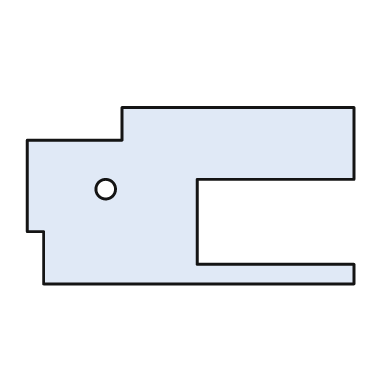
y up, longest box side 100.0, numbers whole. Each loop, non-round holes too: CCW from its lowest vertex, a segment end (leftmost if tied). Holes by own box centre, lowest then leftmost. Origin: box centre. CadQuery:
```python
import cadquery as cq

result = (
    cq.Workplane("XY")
    .moveTo(-45.0, -27.0)
    .lineTo(50.0, -27.0)
    .lineTo(50.0, -21.0)
    .lineTo(2.0, -21.0)
    .lineTo(2.0, 5.0)
    .lineTo(50.0, 5.0)
    .lineTo(50.0, 27.0)
    .lineTo(-21.0, 27.0)
    .lineTo(-21.0, 17.0)
    .lineTo(-50.0, 17.0)
    .lineTo(-50.0, -11.0)
    .lineTo(-45.0, -11.0)
    .close()
    .moveTo(-26.0, 2.0)
    .circle(3.0)
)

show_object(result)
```